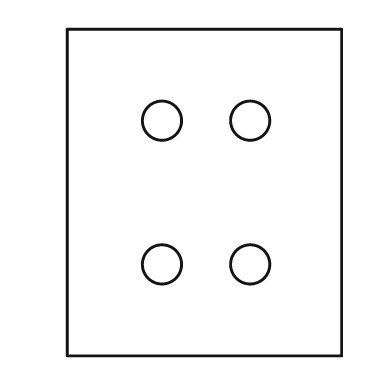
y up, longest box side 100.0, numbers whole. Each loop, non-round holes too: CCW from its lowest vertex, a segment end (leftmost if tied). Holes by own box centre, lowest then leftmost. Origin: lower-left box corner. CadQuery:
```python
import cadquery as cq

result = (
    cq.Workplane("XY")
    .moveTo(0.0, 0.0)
    .lineTo(84.0, 0.0)
    .lineTo(84.0, 100.0)
    .lineTo(0.0, 100.0)
    .close()
    .moveTo(29.0, 28.0)
    .circle(6.0)
    .moveTo(56.0, 28.0)
    .circle(6.0)
    .moveTo(29.0, 72.0)
    .circle(6.0)
    .moveTo(56.0, 72.0)
    .circle(6.0)
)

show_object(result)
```